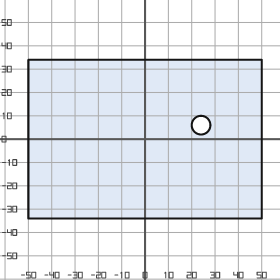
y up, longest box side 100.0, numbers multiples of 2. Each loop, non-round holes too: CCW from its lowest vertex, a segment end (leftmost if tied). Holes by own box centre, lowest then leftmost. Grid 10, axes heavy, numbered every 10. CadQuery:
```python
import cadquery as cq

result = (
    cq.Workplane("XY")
    .moveTo(-50.0, -34.0)
    .lineTo(50.0, -34.0)
    .lineTo(50.0, 34.0)
    .lineTo(-50.0, 34.0)
    .close()
    .moveTo(24.0, 6.0)
    .circle(4.0)
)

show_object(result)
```